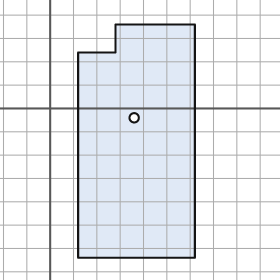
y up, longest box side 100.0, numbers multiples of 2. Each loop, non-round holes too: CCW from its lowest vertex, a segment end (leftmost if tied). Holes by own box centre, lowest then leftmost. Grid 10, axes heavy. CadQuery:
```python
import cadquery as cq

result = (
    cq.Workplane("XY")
    .moveTo(12.0, -64.0)
    .lineTo(62.0, -64.0)
    .lineTo(62.0, 36.0)
    .lineTo(28.0, 36.0)
    .lineTo(28.0, 24.0)
    .lineTo(12.0, 24.0)
    .close()
    .moveTo(36.0, -4.0)
    .circle(2.0)
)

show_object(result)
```